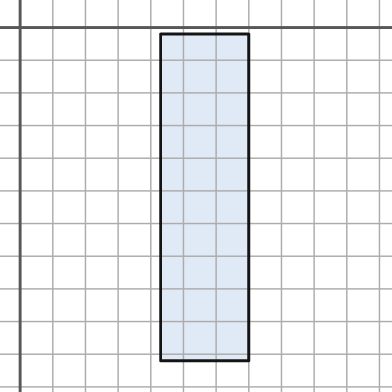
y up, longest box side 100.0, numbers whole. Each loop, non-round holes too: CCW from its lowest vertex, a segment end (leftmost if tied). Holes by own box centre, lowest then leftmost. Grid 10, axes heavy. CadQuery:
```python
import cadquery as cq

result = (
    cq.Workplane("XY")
    .moveTo(43.0, -102.0)
    .lineTo(70.0, -102.0)
    .lineTo(70.0, -2.0)
    .lineTo(43.0, -2.0)
    .close()
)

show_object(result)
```